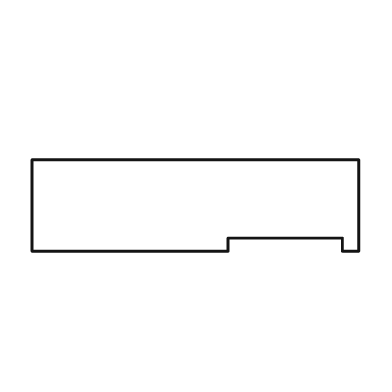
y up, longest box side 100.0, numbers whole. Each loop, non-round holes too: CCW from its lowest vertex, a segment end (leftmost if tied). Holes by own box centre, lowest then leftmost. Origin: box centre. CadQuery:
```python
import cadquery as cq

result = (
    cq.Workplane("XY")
    .moveTo(-50.0, -14.0)
    .lineTo(10.0, -14.0)
    .lineTo(10.0, -10.0)
    .lineTo(45.0, -10.0)
    .lineTo(45.0, -14.0)
    .lineTo(50.0, -14.0)
    .lineTo(50.0, 14.0)
    .lineTo(-50.0, 14.0)
    .close()
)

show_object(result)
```